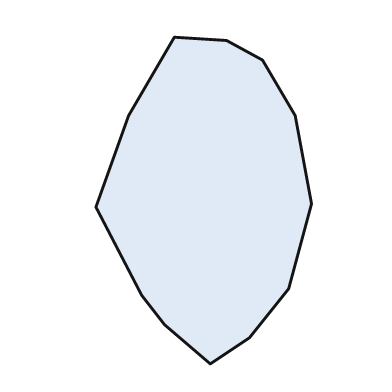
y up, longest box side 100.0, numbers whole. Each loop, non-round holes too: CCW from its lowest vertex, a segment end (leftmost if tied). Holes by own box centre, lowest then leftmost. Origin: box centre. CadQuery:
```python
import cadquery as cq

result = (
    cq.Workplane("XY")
    .moveTo(2.0, -50.0)
    .lineTo(14.0, -42.0)
    .lineTo(26.0, -27.0)
    .lineTo(33.0, -1.0)
    .lineTo(28.0, 26.0)
    .lineTo(18.0, 43.0)
    .lineTo(7.0, 49.0)
    .lineTo(-9.0, 50.0)
    .lineTo(-23.0, 26.0)
    .lineTo(-33.0, -2.0)
    .lineTo(-19.0, -29.0)
    .lineTo(-12.0, -38.0)
    .close()
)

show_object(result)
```